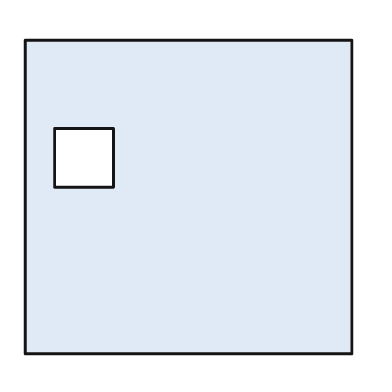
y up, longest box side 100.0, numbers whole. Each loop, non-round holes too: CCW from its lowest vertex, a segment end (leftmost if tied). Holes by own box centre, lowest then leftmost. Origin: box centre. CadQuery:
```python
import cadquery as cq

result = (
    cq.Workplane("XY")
    .moveTo(-50.0, -48.0)
    .lineTo(50.0, -48.0)
    .lineTo(50.0, 48.0)
    .lineTo(-50.0, 48.0)
    .close()
    .moveTo(-41.0, 3.0)
    .lineTo(-23.0, 3.0)
    .lineTo(-23.0, 21.0)
    .lineTo(-41.0, 21.0)
    .close()
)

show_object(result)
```